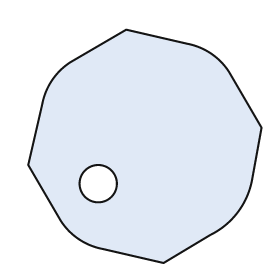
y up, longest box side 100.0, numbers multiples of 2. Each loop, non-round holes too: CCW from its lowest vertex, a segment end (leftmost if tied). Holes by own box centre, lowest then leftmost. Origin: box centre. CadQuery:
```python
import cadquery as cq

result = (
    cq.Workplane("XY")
    .moveTo(8.0, -50.0)
    .lineTo(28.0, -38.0)
    .threePointArc((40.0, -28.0), (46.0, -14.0))
    .lineTo(50.0, 8.0)
    .lineTo(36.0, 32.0)
    .threePointArc((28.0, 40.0), (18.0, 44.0))
    .lineTo(-8.0, 50.0)
    .lineTo(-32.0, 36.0)
    .threePointArc((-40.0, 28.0), (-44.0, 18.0))
    .lineTo(-50.0, -8.0)
    .lineTo(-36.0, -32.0)
    .threePointArc((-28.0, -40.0), (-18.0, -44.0))
    .close()
    .moveTo(-20.0, -16.0)
    .circle(8.0)
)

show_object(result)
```